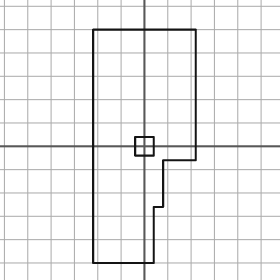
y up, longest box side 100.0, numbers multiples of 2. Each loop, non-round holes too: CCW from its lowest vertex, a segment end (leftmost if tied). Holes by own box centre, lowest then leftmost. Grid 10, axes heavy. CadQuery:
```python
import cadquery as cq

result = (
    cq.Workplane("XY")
    .moveTo(-22.0, -50.0)
    .lineTo(4.0, -50.0)
    .lineTo(4.0, -26.0)
    .lineTo(8.0, -26.0)
    .lineTo(8.0, -6.0)
    .lineTo(22.0, -6.0)
    .lineTo(22.0, 50.0)
    .lineTo(-22.0, 50.0)
    .close()
    .moveTo(-4.0, -4.0)
    .lineTo(4.0, -4.0)
    .lineTo(4.0, 4.0)
    .lineTo(-4.0, 4.0)
    .close()
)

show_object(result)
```